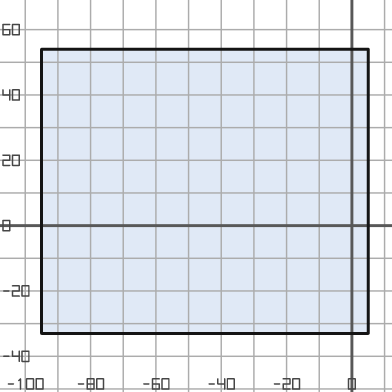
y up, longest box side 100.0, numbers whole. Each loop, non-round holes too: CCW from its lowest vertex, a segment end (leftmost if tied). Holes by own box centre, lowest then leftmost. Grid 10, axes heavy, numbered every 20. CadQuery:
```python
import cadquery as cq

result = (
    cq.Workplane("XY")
    .moveTo(-95.0, -33.0)
    .lineTo(5.0, -33.0)
    .lineTo(5.0, 54.0)
    .lineTo(-95.0, 54.0)
    .close()
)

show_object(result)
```